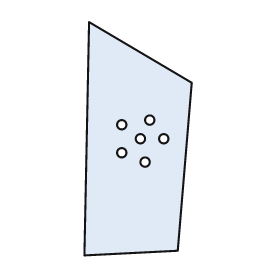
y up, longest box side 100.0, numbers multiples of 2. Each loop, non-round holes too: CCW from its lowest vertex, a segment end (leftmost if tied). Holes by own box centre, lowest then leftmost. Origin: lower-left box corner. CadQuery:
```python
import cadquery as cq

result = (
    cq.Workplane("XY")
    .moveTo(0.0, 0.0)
    .lineTo(40.0, 2.0)
    .lineTo(46.0, 74.0)
    .lineTo(2.0, 100.0)
    .close()
    .moveTo(26.0, 40.0)
    .circle(2.0)
    .moveTo(16.0, 44.0)
    .circle(2.0)
    .moveTo(24.0, 50.0)
    .circle(2.0)
    .moveTo(34.0, 50.0)
    .circle(2.0)
    .moveTo(16.0, 56.0)
    .circle(2.0)
    .moveTo(28.0, 58.0)
    .circle(2.0)
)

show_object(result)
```